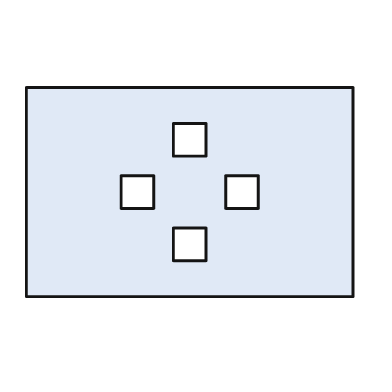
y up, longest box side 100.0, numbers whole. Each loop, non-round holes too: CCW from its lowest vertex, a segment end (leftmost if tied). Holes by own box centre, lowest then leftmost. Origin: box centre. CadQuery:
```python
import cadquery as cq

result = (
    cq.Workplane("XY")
    .moveTo(-50.0, -32.0)
    .lineTo(50.0, -32.0)
    .lineTo(50.0, 32.0)
    .lineTo(-50.0, 32.0)
    .close()
    .moveTo(-5.0, -21.0)
    .lineTo(5.0, -21.0)
    .lineTo(5.0, -11.0)
    .lineTo(-5.0, -11.0)
    .close()
    .moveTo(-21.0, -5.0)
    .lineTo(-11.0, -5.0)
    .lineTo(-11.0, 5.0)
    .lineTo(-21.0, 5.0)
    .close()
    .moveTo(11.0, -5.0)
    .lineTo(21.0, -5.0)
    .lineTo(21.0, 5.0)
    .lineTo(11.0, 5.0)
    .close()
    .moveTo(-5.0, 11.0)
    .lineTo(5.0, 11.0)
    .lineTo(5.0, 21.0)
    .lineTo(-5.0, 21.0)
    .close()
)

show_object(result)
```